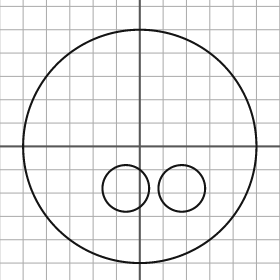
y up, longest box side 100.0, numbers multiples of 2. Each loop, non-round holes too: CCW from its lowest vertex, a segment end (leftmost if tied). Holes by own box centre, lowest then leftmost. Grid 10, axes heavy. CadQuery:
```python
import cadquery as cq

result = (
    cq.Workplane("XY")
    .moveTo(0.0, 0.0)
    .circle(50.0)
    .moveTo(-6.0, -18.0)
    .circle(10.0)
    .moveTo(18.0, -18.0)
    .circle(10.0)
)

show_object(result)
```